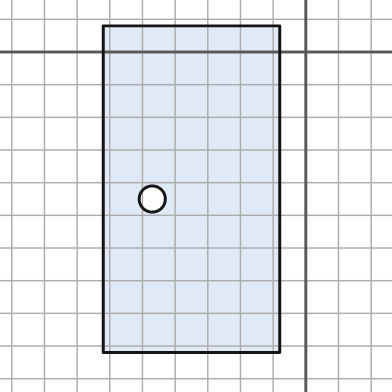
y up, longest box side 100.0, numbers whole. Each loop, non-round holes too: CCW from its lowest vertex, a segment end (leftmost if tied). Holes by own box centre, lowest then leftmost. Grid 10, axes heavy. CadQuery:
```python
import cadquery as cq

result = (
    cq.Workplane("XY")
    .moveTo(-62.0, -92.0)
    .lineTo(-8.0, -92.0)
    .lineTo(-8.0, 8.0)
    .lineTo(-62.0, 8.0)
    .close()
    .moveTo(-47.0, -45.0)
    .circle(4.0)
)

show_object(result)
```